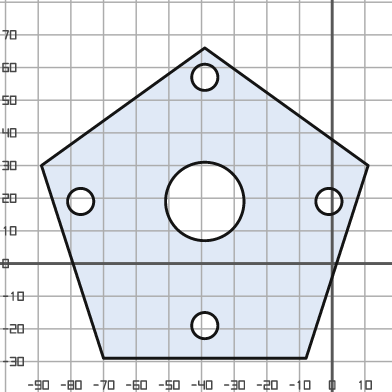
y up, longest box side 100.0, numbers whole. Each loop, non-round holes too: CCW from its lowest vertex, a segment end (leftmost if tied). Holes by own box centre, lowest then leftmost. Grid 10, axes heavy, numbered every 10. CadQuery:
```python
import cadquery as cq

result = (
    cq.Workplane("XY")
    .moveTo(-70.0, -29.0)
    .lineTo(-8.0, -29.0)
    .lineTo(11.0, 30.0)
    .lineTo(-39.0, 66.0)
    .lineTo(-89.0, 30.0)
    .close()
    .moveTo(-39.0, -19.0)
    .circle(4.0)
    .moveTo(-77.0, 19.0)
    .circle(4.0)
    .moveTo(-39.0, 19.0)
    .circle(12.0)
    .moveTo(-1.0, 19.0)
    .circle(4.0)
    .moveTo(-39.0, 57.0)
    .circle(4.0)
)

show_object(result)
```